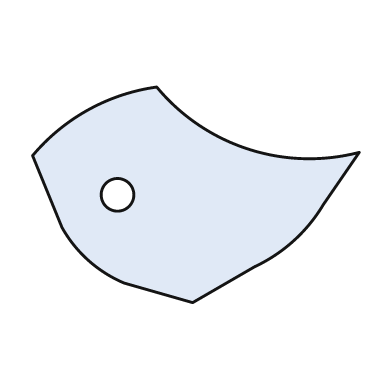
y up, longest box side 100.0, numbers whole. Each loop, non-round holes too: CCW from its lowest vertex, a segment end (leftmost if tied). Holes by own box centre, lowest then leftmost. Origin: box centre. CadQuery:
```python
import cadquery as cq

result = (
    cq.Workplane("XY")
    .moveTo(-1.0, -33.0)
    .lineTo(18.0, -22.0)
    .threePointArc((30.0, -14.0), (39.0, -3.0))
    .lineTo(50.0, 13.0)
    .threePointArc((16.0, 14.0), (-12.0, 33.0))
    .threePointArc((-33.0, 26.0), (-50.0, 12.0))
    .lineTo(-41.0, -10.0)
    .threePointArc((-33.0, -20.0), (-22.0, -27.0))
    .close()
    .moveTo(-24.0, 0.0)
    .circle(5.0)
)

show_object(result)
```